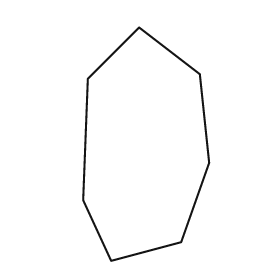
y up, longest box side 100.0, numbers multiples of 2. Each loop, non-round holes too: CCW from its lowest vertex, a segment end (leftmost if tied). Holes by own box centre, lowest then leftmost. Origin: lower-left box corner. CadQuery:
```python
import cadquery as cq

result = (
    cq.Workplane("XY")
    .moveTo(12.0, 0.0)
    .lineTo(42.0, 8.0)
    .lineTo(54.0, 42.0)
    .lineTo(50.0, 80.0)
    .lineTo(24.0, 100.0)
    .lineTo(2.0, 78.0)
    .lineTo(0.0, 26.0)
    .close()
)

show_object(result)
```